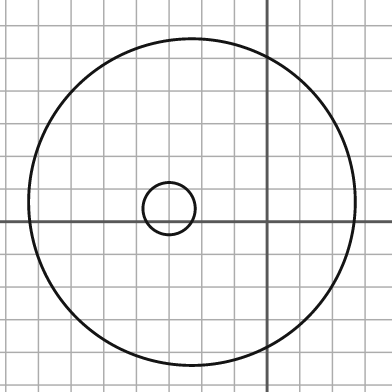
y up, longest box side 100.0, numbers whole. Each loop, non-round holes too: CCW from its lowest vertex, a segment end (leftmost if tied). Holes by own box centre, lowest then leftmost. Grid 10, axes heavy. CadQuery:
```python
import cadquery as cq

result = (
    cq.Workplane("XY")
    .moveTo(-23.0, 6.0)
    .circle(50.0)
    .moveTo(-30.0, 4.0)
    .circle(8.0)
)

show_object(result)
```